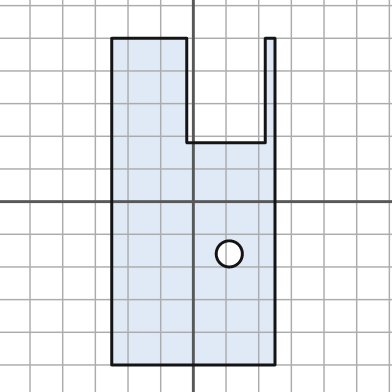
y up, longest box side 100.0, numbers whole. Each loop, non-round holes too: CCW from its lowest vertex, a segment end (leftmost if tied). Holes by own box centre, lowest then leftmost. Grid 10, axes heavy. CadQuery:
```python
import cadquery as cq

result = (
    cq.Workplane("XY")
    .moveTo(-25.0, -50.0)
    .lineTo(25.0, -50.0)
    .lineTo(25.0, 50.0)
    .lineTo(22.0, 50.0)
    .lineTo(22.0, 18.0)
    .lineTo(-2.0, 18.0)
    .lineTo(-2.0, 50.0)
    .lineTo(-25.0, 50.0)
    .close()
    .moveTo(11.0, -16.0)
    .circle(4.0)
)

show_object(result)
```